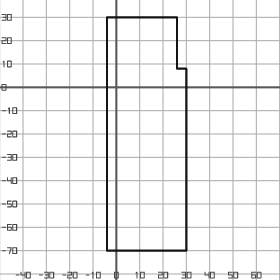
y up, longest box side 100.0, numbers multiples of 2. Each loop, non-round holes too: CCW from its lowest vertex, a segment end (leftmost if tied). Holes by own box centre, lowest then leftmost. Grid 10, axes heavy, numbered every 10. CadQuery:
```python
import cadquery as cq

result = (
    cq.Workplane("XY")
    .moveTo(-4.0, -70.0)
    .lineTo(30.0, -70.0)
    .lineTo(30.0, 8.0)
    .lineTo(26.0, 8.0)
    .lineTo(26.0, 30.0)
    .lineTo(-4.0, 30.0)
    .close()
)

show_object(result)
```